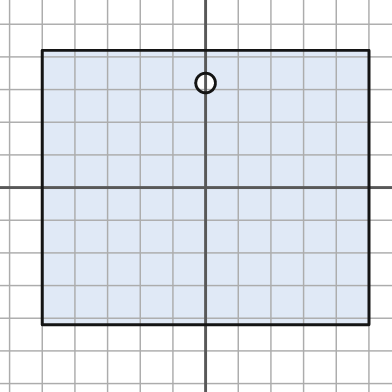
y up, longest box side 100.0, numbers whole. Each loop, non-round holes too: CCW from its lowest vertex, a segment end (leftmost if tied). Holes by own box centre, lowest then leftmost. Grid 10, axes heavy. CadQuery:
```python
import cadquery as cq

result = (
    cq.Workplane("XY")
    .moveTo(-50.0, -42.0)
    .lineTo(50.0, -42.0)
    .lineTo(50.0, 42.0)
    .lineTo(-50.0, 42.0)
    .close()
    .moveTo(0.0, 32.0)
    .circle(3.0)
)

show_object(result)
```